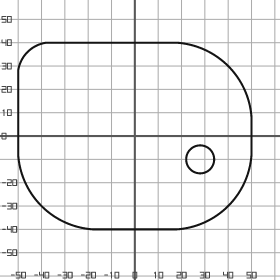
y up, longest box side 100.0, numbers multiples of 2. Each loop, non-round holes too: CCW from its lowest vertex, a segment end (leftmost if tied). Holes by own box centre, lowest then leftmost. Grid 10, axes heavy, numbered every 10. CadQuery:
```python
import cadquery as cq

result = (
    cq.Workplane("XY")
    .moveTo(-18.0, -40.0)
    .lineTo(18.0, -40.0)
    .threePointArc((40.0, -30.0), (50.0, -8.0))
    .lineTo(50.0, 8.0)
    .threePointArc((40.0, 30.0), (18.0, 40.0))
    .lineTo(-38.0, 40.0)
    .threePointArc((-46.0, 36.0), (-50.0, 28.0))
    .lineTo(-50.0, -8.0)
    .threePointArc((-40.0, -30.0), (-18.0, -40.0))
    .close()
    .moveTo(28.0, -10.0)
    .circle(6.0)
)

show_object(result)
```